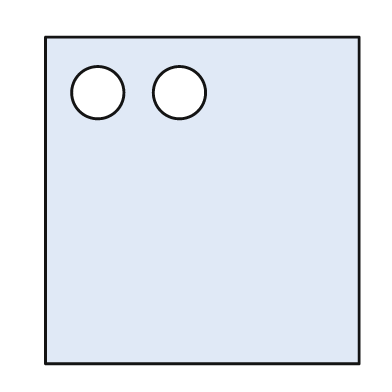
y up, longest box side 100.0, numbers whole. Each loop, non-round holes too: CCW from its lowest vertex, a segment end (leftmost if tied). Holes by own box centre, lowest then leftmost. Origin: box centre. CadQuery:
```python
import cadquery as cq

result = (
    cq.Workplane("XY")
    .moveTo(-48.0, -50.0)
    .lineTo(48.0, -50.0)
    .lineTo(48.0, 50.0)
    .lineTo(-48.0, 50.0)
    .close()
    .moveTo(-32.0, 33.0)
    .circle(8.0)
    .moveTo(-7.0, 33.0)
    .circle(8.0)
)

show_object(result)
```